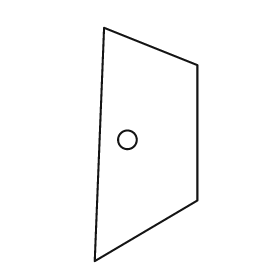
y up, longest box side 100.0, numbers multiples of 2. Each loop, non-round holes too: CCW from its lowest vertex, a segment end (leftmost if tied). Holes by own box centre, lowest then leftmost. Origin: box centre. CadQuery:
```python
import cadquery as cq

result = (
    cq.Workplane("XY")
    .moveTo(-22.0, -50.0)
    .lineTo(22.0, -24.0)
    .lineTo(22.0, 34.0)
    .lineTo(-18.0, 50.0)
    .close()
    .moveTo(-8.0, 2.0)
    .circle(4.0)
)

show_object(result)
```